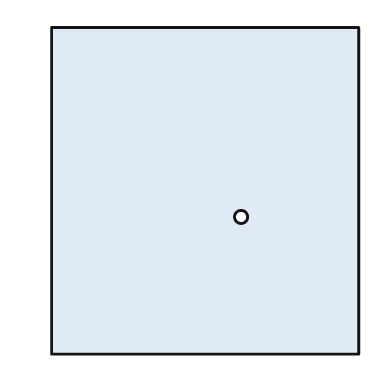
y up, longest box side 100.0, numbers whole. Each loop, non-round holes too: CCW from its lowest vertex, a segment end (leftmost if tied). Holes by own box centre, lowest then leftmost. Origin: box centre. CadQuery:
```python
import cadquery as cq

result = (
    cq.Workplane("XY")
    .moveTo(-47.0, -50.0)
    .lineTo(47.0, -50.0)
    .lineTo(47.0, 50.0)
    .lineTo(-47.0, 50.0)
    .close()
    .moveTo(11.0, -8.0)
    .circle(2.0)
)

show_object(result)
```